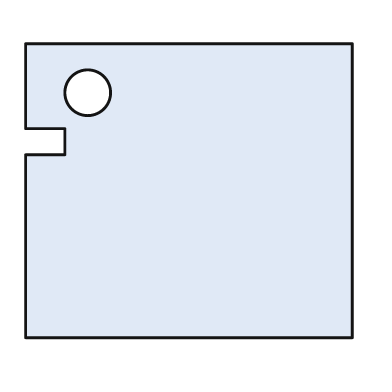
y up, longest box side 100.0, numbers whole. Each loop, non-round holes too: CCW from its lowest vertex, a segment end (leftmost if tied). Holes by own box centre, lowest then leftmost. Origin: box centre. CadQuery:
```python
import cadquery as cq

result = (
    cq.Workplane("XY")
    .moveTo(-50.0, -45.0)
    .lineTo(50.0, -45.0)
    .lineTo(50.0, 45.0)
    .lineTo(-50.0, 45.0)
    .lineTo(-50.0, 19.0)
    .lineTo(-38.0, 19.0)
    .lineTo(-38.0, 11.0)
    .lineTo(-50.0, 11.0)
    .close()
    .moveTo(-31.0, 30.0)
    .circle(7.0)
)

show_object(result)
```